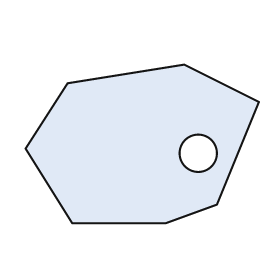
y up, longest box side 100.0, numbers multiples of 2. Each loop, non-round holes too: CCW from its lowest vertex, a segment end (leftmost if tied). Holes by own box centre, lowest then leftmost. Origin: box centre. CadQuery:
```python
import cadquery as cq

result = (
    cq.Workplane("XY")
    .moveTo(-30.0, -34.0)
    .lineTo(10.0, -34.0)
    .lineTo(32.0, -26.0)
    .lineTo(50.0, 18.0)
    .lineTo(18.0, 34.0)
    .lineTo(-32.0, 26.0)
    .lineTo(-50.0, -2.0)
    .close()
    .moveTo(24.0, -4.0)
    .circle(8.0)
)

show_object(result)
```